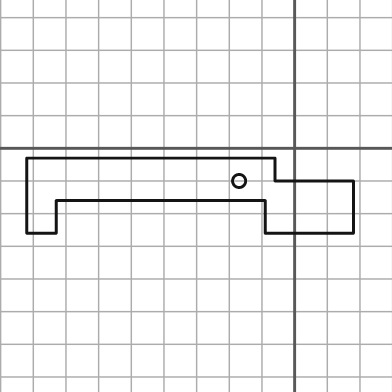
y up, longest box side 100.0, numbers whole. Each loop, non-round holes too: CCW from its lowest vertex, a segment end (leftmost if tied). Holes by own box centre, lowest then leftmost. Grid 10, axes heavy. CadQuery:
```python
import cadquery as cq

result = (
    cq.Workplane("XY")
    .moveTo(-82.0, -26.0)
    .lineTo(-73.0, -26.0)
    .lineTo(-73.0, -16.0)
    .lineTo(-9.0, -16.0)
    .lineTo(-9.0, -26.0)
    .lineTo(18.0, -26.0)
    .lineTo(18.0, -10.0)
    .lineTo(-6.0, -10.0)
    .lineTo(-6.0, -3.0)
    .lineTo(-82.0, -3.0)
    .close()
    .moveTo(-17.0, -10.0)
    .circle(2.0)
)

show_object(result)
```